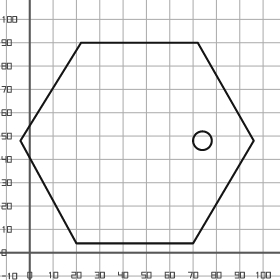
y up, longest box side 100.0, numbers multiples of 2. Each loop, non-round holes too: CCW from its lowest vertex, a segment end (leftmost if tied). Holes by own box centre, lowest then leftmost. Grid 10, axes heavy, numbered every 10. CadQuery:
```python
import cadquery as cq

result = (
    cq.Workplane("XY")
    .moveTo(20.0, 4.0)
    .lineTo(70.0, 4.0)
    .lineTo(96.0, 48.0)
    .lineTo(72.0, 90.0)
    .lineTo(22.0, 90.0)
    .lineTo(-4.0, 48.0)
    .close()
    .moveTo(74.0, 48.0)
    .circle(4.0)
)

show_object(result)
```